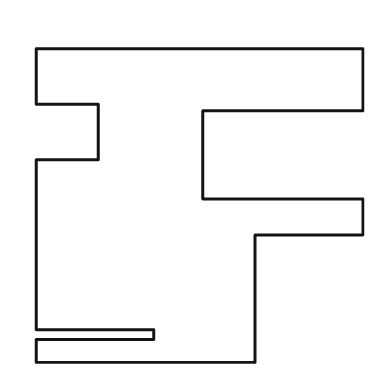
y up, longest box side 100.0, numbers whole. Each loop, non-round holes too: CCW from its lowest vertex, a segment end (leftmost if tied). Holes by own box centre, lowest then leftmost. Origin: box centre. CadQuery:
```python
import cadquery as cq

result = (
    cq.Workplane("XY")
    .moveTo(-50.0, -48.0)
    .lineTo(17.0, -48.0)
    .lineTo(17.0, -9.0)
    .lineTo(50.0, -9.0)
    .lineTo(50.0, 2.0)
    .lineTo(1.0, 2.0)
    .lineTo(1.0, 29.0)
    .lineTo(50.0, 29.0)
    .lineTo(50.0, 48.0)
    .lineTo(-50.0, 48.0)
    .lineTo(-50.0, 31.0)
    .lineTo(-31.0, 31.0)
    .lineTo(-31.0, 14.0)
    .lineTo(-50.0, 14.0)
    .lineTo(-50.0, -38.0)
    .lineTo(-14.0, -38.0)
    .lineTo(-14.0, -41.0)
    .lineTo(-50.0, -41.0)
    .close()
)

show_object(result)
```